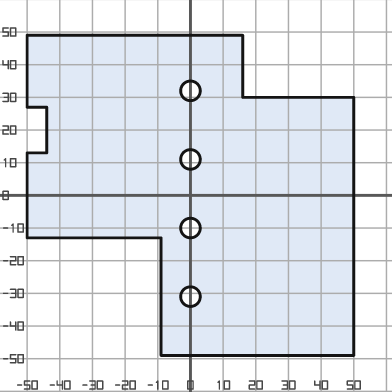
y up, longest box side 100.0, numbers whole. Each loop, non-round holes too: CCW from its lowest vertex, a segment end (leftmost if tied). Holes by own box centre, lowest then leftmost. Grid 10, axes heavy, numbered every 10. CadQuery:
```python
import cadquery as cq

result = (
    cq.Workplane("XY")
    .moveTo(-9.0, -49.0)
    .lineTo(50.0, -49.0)
    .lineTo(50.0, 30.0)
    .lineTo(16.0, 30.0)
    .lineTo(16.0, 49.0)
    .lineTo(-50.0, 49.0)
    .lineTo(-50.0, 27.0)
    .lineTo(-44.0, 27.0)
    .lineTo(-44.0, 13.0)
    .lineTo(-50.0, 13.0)
    .lineTo(-50.0, -13.0)
    .lineTo(-9.0, -13.0)
    .close()
    .moveTo(0.0, -31.0)
    .circle(3.0)
    .moveTo(0.0, -10.0)
    .circle(3.0)
    .moveTo(0.0, 11.0)
    .circle(3.0)
    .moveTo(0.0, 32.0)
    .circle(3.0)
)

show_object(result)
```